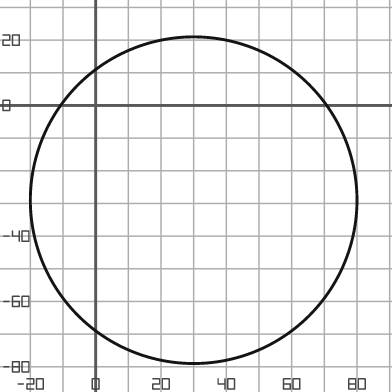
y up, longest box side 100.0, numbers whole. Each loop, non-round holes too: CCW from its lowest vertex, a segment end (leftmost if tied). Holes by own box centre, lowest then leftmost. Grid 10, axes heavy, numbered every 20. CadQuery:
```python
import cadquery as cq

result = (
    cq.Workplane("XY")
    .moveTo(30.0, -29.0)
    .circle(50.0)
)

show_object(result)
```